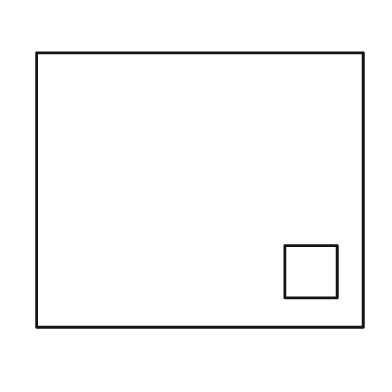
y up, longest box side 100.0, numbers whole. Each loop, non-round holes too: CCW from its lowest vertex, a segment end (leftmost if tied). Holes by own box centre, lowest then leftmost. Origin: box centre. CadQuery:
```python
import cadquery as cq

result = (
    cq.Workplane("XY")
    .moveTo(-50.0, -42.0)
    .lineTo(50.0, -42.0)
    .lineTo(50.0, 42.0)
    .lineTo(-50.0, 42.0)
    .close()
    .moveTo(26.0, -33.0)
    .lineTo(42.0, -33.0)
    .lineTo(42.0, -17.0)
    .lineTo(26.0, -17.0)
    .close()
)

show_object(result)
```